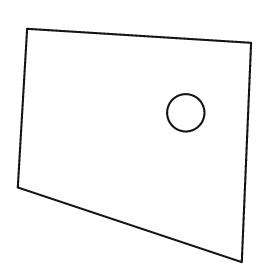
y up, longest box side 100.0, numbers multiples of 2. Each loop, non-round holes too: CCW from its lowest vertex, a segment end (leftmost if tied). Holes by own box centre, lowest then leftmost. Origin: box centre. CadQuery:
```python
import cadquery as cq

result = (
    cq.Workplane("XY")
    .moveTo(46.0, -50.0)
    .lineTo(50.0, 44.0)
    .lineTo(-46.0, 50.0)
    .lineTo(-50.0, -18.0)
    .close()
    .moveTo(22.0, 14.0)
    .circle(8.0)
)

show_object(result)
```